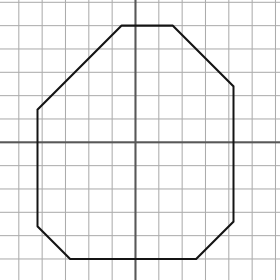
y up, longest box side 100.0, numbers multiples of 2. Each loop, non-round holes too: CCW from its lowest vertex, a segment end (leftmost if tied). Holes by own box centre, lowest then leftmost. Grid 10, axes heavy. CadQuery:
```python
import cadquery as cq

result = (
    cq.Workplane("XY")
    .moveTo(-28.0, -50.0)
    .lineTo(26.0, -50.0)
    .lineTo(42.0, -34.0)
    .lineTo(42.0, 24.0)
    .lineTo(16.0, 50.0)
    .lineTo(-6.0, 50.0)
    .lineTo(-42.0, 14.0)
    .lineTo(-42.0, -36.0)
    .close()
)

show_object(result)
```